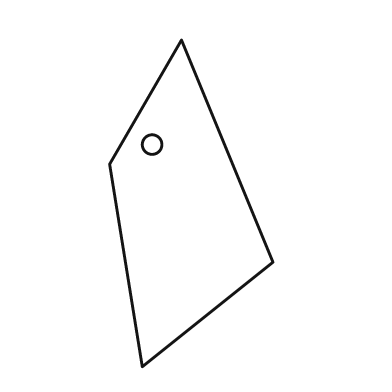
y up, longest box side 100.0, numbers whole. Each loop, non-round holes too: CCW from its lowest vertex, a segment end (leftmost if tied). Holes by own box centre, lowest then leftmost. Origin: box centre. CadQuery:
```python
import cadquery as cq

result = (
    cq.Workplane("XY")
    .moveTo(-15.0, -50.0)
    .lineTo(25.0, -18.0)
    .lineTo(-3.0, 50.0)
    .lineTo(-25.0, 12.0)
    .close()
    .moveTo(-12.0, 18.0)
    .circle(3.0)
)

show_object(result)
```